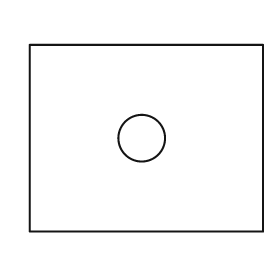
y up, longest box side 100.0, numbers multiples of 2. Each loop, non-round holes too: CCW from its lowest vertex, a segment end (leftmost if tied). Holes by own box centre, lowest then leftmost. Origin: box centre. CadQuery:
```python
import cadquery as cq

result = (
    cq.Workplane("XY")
    .moveTo(-50.0, -40.0)
    .lineTo(50.0, -40.0)
    .lineTo(50.0, 40.0)
    .lineTo(-50.0, 40.0)
    .close()
    .moveTo(-2.0, 0.0)
    .circle(10.0)
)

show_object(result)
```